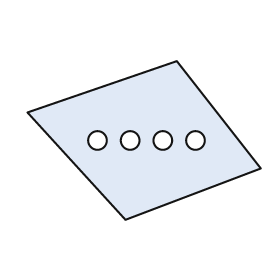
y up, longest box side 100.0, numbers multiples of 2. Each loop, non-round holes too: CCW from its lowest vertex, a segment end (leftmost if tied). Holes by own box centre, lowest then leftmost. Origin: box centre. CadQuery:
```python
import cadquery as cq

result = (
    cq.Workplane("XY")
    .moveTo(-8.0, -34.0)
    .lineTo(50.0, -12.0)
    .lineTo(14.0, 34.0)
    .lineTo(-50.0, 12.0)
    .close()
    .moveTo(-20.0, 0.0)
    .circle(4.0)
    .moveTo(-6.0, 0.0)
    .circle(4.0)
    .moveTo(8.0, 0.0)
    .circle(4.0)
    .moveTo(22.0, 0.0)
    .circle(4.0)
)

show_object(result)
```